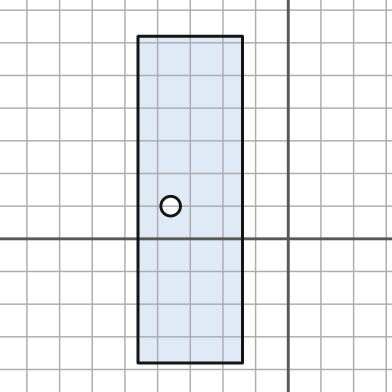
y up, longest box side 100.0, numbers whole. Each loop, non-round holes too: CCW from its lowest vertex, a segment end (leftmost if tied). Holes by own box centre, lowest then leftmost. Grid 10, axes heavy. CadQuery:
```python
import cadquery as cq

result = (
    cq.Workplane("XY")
    .moveTo(-46.0, -38.0)
    .lineTo(-14.0, -38.0)
    .lineTo(-14.0, 62.0)
    .lineTo(-46.0, 62.0)
    .close()
    .moveTo(-36.0, 10.0)
    .circle(3.0)
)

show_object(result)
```